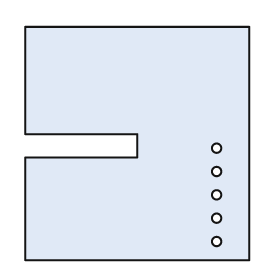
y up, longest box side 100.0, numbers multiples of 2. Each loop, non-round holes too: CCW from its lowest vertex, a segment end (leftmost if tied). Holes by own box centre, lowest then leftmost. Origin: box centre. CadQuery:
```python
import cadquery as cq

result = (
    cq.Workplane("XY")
    .moveTo(-48.0, -50.0)
    .lineTo(48.0, -50.0)
    .lineTo(48.0, 50.0)
    .lineTo(-48.0, 50.0)
    .lineTo(-48.0, 4.0)
    .lineTo(0.0, 4.0)
    .lineTo(0.0, -6.0)
    .lineTo(-48.0, -6.0)
    .close()
    .moveTo(34.0, -42.0)
    .circle(2.0)
    .moveTo(34.0, -32.0)
    .circle(2.0)
    .moveTo(34.0, -22.0)
    .circle(2.0)
    .moveTo(34.0, -12.0)
    .circle(2.0)
    .moveTo(34.0, -2.0)
    .circle(2.0)
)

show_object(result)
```